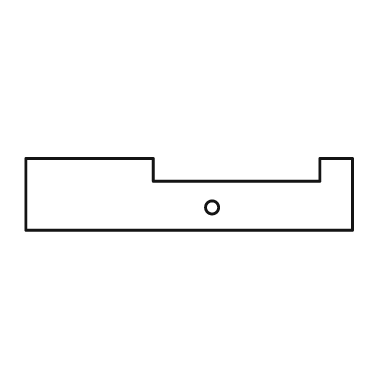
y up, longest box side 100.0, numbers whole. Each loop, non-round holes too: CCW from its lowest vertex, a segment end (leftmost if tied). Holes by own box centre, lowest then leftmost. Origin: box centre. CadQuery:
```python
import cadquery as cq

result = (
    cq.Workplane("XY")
    .moveTo(-50.0, -11.0)
    .lineTo(50.0, -11.0)
    .lineTo(50.0, 11.0)
    .lineTo(40.0, 11.0)
    .lineTo(40.0, 4.0)
    .lineTo(-11.0, 4.0)
    .lineTo(-11.0, 11.0)
    .lineTo(-50.0, 11.0)
    .close()
    .moveTo(7.0, -4.0)
    .circle(2.0)
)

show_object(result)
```